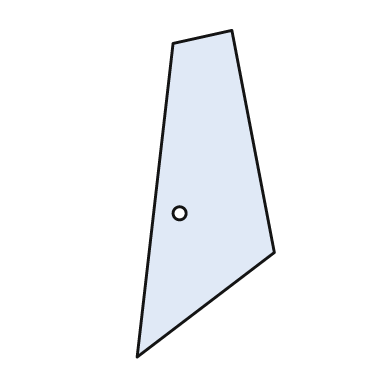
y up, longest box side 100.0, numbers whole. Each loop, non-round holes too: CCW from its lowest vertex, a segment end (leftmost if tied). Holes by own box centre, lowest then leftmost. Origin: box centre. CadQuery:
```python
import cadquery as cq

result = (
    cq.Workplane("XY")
    .moveTo(-21.0, -50.0)
    .lineTo(21.0, -18.0)
    .lineTo(8.0, 50.0)
    .lineTo(-10.0, 46.0)
    .close()
    .moveTo(-8.0, -6.0)
    .circle(2.0)
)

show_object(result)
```